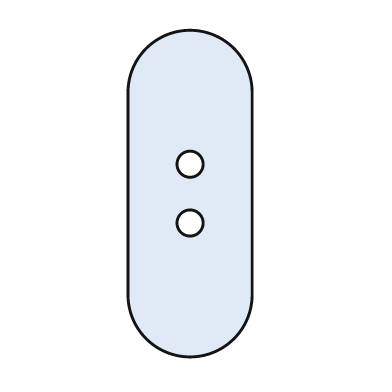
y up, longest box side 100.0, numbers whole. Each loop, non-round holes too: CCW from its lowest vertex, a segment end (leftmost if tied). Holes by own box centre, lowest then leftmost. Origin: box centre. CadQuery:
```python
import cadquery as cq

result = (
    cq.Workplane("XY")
    .moveTo(-19.0, -31.0)
    .threePointArc((0.0, -50.0), (19.0, -31.0))
    .lineTo(19.0, 31.0)
    .threePointArc((0.0, 50.0), (-19.0, 31.0))
    .close()
    .moveTo(0.0, -9.0)
    .circle(4.0)
    .moveTo(0.0, 9.0)
    .circle(4.0)
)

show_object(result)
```